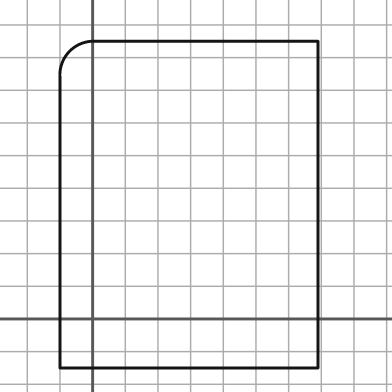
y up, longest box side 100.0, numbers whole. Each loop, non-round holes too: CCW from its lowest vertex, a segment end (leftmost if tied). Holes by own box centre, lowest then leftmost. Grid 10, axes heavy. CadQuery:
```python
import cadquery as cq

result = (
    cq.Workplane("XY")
    .moveTo(-10.0, -15.0)
    .lineTo(69.0, -15.0)
    .lineTo(69.0, 85.0)
    .lineTo(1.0, 85.0)
    .threePointArc((-7.0, 82.0), (-10.0, 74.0))
    .close()
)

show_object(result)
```